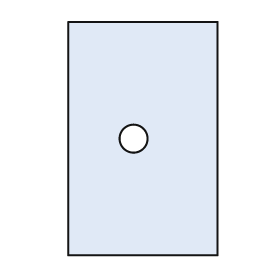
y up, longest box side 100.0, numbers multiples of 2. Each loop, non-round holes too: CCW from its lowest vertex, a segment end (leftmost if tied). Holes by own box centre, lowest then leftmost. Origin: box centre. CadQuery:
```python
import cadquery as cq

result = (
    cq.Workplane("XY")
    .moveTo(-32.0, -50.0)
    .lineTo(32.0, -50.0)
    .lineTo(32.0, 50.0)
    .lineTo(-32.0, 50.0)
    .close()
    .moveTo(-4.0, 0.0)
    .circle(6.0)
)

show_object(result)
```